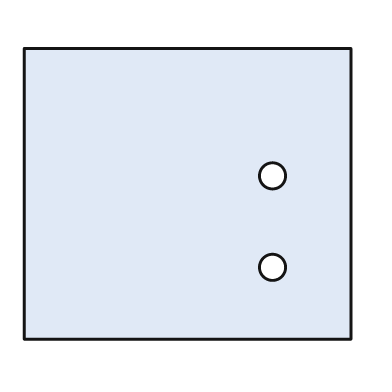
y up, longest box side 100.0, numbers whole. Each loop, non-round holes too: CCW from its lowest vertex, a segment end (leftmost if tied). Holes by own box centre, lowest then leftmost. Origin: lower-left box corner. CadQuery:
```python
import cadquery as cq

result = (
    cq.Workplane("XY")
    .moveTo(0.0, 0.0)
    .lineTo(100.0, 0.0)
    .lineTo(100.0, 89.0)
    .lineTo(0.0, 89.0)
    .close()
    .moveTo(76.0, 22.0)
    .circle(4.0)
    .moveTo(76.0, 50.0)
    .circle(4.0)
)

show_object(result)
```